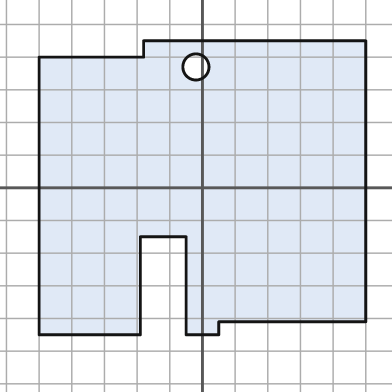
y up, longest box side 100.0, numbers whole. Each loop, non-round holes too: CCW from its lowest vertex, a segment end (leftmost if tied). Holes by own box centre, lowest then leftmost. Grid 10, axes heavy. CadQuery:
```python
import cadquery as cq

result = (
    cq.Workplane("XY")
    .moveTo(-50.0, -45.0)
    .lineTo(-19.0, -45.0)
    .lineTo(-19.0, -15.0)
    .lineTo(-5.0, -15.0)
    .lineTo(-5.0, -45.0)
    .lineTo(5.0, -45.0)
    .lineTo(5.0, -41.0)
    .lineTo(50.0, -41.0)
    .lineTo(50.0, 45.0)
    .lineTo(-18.0, 45.0)
    .lineTo(-18.0, 40.0)
    .lineTo(-50.0, 40.0)
    .close()
    .moveTo(-2.0, 37.0)
    .circle(4.0)
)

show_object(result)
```